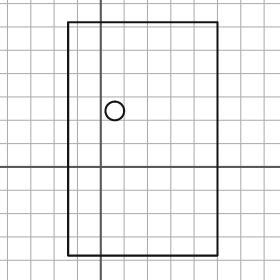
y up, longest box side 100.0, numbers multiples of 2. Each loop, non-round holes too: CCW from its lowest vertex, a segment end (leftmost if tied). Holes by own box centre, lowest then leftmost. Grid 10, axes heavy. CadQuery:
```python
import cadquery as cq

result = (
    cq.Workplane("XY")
    .moveTo(-14.0, -38.0)
    .lineTo(50.0, -38.0)
    .lineTo(50.0, 62.0)
    .lineTo(-14.0, 62.0)
    .close()
    .moveTo(6.0, 24.0)
    .circle(4.0)
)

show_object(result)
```